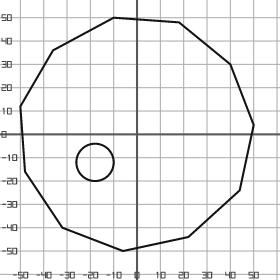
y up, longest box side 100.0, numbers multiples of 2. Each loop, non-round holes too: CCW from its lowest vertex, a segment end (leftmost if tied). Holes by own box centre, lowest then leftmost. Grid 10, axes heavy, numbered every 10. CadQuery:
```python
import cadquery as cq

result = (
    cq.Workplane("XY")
    .moveTo(-6.0, -50.0)
    .lineTo(22.0, -44.0)
    .lineTo(44.0, -24.0)
    .lineTo(50.0, 4.0)
    .lineTo(40.0, 30.0)
    .lineTo(18.0, 48.0)
    .lineTo(-10.0, 50.0)
    .lineTo(-36.0, 36.0)
    .lineTo(-50.0, 12.0)
    .lineTo(-48.0, -16.0)
    .lineTo(-32.0, -40.0)
    .close()
    .moveTo(-18.0, -12.0)
    .circle(8.0)
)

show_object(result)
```